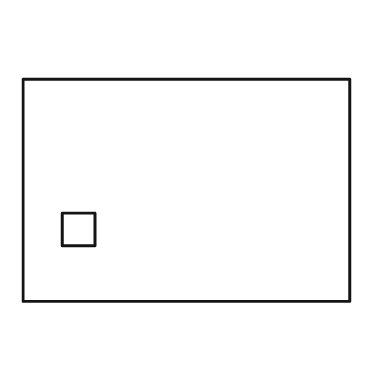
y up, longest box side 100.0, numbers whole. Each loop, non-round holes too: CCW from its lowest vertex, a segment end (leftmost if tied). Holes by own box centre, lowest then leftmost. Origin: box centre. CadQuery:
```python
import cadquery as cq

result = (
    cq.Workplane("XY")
    .moveTo(-50.0, -34.0)
    .lineTo(50.0, -34.0)
    .lineTo(50.0, 34.0)
    .lineTo(-50.0, 34.0)
    .close()
    .moveTo(-38.0, -17.0)
    .lineTo(-28.0, -17.0)
    .lineTo(-28.0, -7.0)
    .lineTo(-38.0, -7.0)
    .close()
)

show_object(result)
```